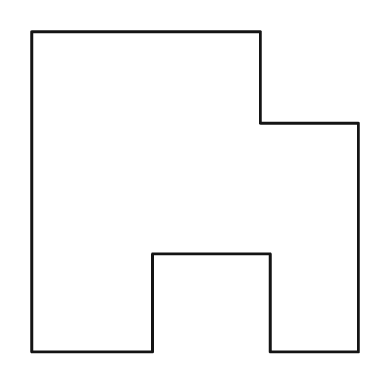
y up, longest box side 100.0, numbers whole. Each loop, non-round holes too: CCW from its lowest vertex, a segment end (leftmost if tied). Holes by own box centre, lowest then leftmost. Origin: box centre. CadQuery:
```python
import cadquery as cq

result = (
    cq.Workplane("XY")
    .moveTo(-50.0, -49.0)
    .lineTo(-13.0, -49.0)
    .lineTo(-13.0, -19.0)
    .lineTo(23.0, -19.0)
    .lineTo(23.0, -49.0)
    .lineTo(50.0, -49.0)
    .lineTo(50.0, 21.0)
    .lineTo(20.0, 21.0)
    .lineTo(20.0, 49.0)
    .lineTo(-50.0, 49.0)
    .close()
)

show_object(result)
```